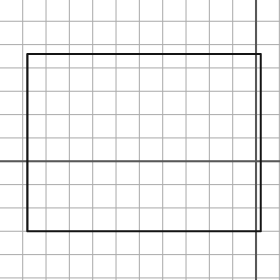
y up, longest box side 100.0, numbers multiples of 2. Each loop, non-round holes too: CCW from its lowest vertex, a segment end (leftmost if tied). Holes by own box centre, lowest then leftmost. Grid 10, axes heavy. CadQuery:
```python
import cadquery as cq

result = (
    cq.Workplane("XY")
    .moveTo(-98.0, -30.0)
    .lineTo(2.0, -30.0)
    .lineTo(2.0, 46.0)
    .lineTo(-98.0, 46.0)
    .close()
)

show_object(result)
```